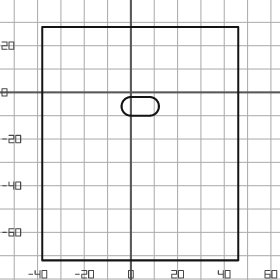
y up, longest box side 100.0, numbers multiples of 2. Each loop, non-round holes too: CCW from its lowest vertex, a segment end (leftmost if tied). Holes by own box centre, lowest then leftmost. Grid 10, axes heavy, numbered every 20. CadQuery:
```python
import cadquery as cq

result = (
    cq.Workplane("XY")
    .moveTo(-38.0, -72.0)
    .lineTo(46.0, -72.0)
    .lineTo(46.0, 28.0)
    .lineTo(-38.0, 28.0)
    .close()
    .moveTo(0.0, -10.0)
    .lineTo(8.0, -10.0)
    .threePointArc((12.0, -6.0), (8.0, -2.0))
    .lineTo(0.0, -2.0)
    .threePointArc((-4.0, -6.0), (0.0, -10.0))
    .close()
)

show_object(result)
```